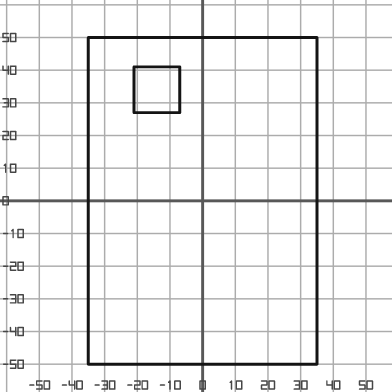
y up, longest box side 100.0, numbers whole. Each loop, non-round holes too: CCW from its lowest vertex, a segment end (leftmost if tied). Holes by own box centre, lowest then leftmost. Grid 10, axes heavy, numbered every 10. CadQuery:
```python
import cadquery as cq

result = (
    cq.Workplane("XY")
    .moveTo(-35.0, -50.0)
    .lineTo(35.0, -50.0)
    .lineTo(35.0, 50.0)
    .lineTo(-35.0, 50.0)
    .close()
    .moveTo(-21.0, 27.0)
    .lineTo(-7.0, 27.0)
    .lineTo(-7.0, 41.0)
    .lineTo(-21.0, 41.0)
    .close()
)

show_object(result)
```